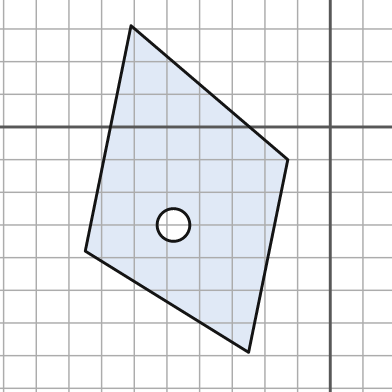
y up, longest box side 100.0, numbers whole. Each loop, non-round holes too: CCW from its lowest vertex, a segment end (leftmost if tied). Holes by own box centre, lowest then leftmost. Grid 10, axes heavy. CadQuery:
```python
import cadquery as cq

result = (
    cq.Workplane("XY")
    .moveTo(-25.0, -69.0)
    .lineTo(-13.0, -10.0)
    .lineTo(-61.0, 31.0)
    .lineTo(-75.0, -38.0)
    .close()
    .moveTo(-48.0, -30.0)
    .circle(5.0)
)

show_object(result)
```